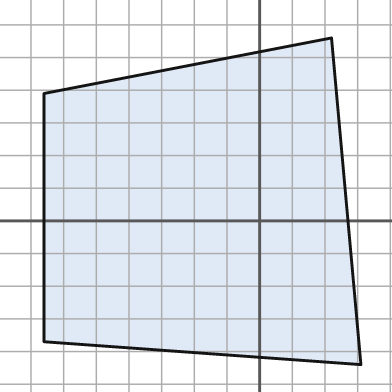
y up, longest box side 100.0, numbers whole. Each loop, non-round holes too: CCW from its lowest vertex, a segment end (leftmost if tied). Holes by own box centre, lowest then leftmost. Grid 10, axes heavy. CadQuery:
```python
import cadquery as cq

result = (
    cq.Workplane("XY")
    .moveTo(31.0, -44.0)
    .lineTo(22.0, 56.0)
    .lineTo(-66.0, 39.0)
    .lineTo(-66.0, -37.0)
    .close()
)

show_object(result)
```